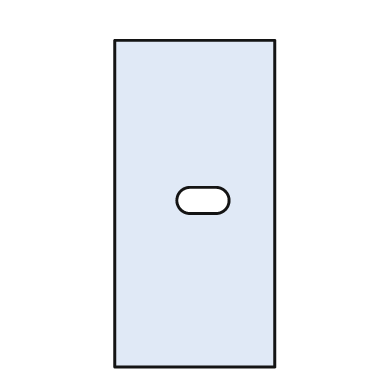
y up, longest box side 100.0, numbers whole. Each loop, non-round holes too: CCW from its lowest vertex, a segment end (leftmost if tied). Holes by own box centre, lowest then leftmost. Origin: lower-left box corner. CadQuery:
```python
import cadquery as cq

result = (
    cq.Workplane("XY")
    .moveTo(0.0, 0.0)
    .lineTo(49.0, 0.0)
    .lineTo(49.0, 100.0)
    .lineTo(0.0, 100.0)
    .close()
    .moveTo(23.0, 47.0)
    .lineTo(31.0, 47.0)
    .threePointArc((35.0, 51.0), (31.0, 55.0))
    .lineTo(23.0, 55.0)
    .threePointArc((19.0, 51.0), (23.0, 47.0))
    .close()
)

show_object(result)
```